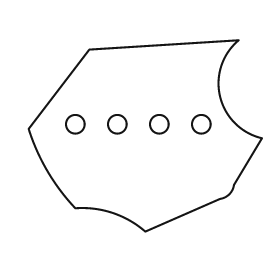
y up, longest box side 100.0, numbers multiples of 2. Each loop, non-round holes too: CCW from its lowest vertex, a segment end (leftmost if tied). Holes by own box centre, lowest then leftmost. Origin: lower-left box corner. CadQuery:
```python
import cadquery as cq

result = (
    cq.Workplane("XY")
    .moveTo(50.0, 0.0)
    .lineTo(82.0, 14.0)
    .threePointArc((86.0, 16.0), (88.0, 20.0))
    .lineTo(100.0, 40.0)
    .threePointArc((82.0, 58.0), (90.0, 82.0))
    .lineTo(26.0, 78.0)
    .lineTo(0.0, 44.0)
    .threePointArc((8.0, 26.0), (20.0, 10.0))
    .threePointArc((36.0, 8.0), (50.0, 0.0))
    .close()
    .moveTo(20.0, 46.0)
    .circle(4.0)
    .moveTo(38.0, 46.0)
    .circle(4.0)
    .moveTo(56.0, 46.0)
    .circle(4.0)
    .moveTo(74.0, 46.0)
    .circle(4.0)
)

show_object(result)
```